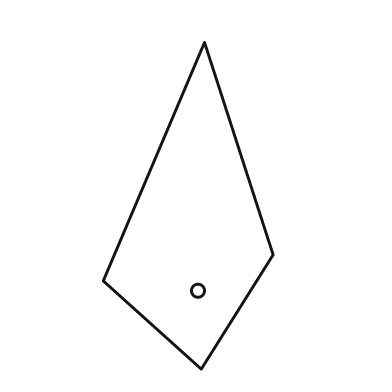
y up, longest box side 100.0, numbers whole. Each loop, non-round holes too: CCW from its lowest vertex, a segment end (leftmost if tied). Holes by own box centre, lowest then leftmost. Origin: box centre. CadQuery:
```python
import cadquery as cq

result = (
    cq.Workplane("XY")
    .moveTo(4.0, -50.0)
    .lineTo(26.0, -15.0)
    .lineTo(5.0, 50.0)
    .lineTo(-26.0, -23.0)
    .close()
    .moveTo(3.0, -26.0)
    .circle(2.0)
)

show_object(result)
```